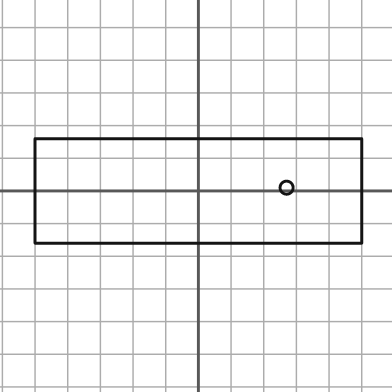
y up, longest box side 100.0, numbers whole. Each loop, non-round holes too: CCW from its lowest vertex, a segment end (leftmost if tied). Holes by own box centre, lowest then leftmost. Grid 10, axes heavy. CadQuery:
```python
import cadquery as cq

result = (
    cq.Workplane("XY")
    .moveTo(-50.0, -16.0)
    .lineTo(50.0, -16.0)
    .lineTo(50.0, 16.0)
    .lineTo(-50.0, 16.0)
    .close()
    .moveTo(27.0, 1.0)
    .circle(2.0)
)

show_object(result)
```